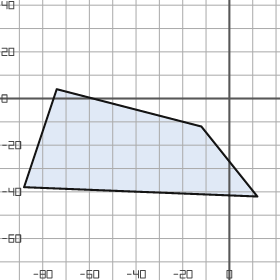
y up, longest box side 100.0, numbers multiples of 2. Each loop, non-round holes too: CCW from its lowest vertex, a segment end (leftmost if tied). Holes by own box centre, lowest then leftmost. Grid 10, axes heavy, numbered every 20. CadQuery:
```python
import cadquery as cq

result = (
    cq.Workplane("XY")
    .moveTo(12.0, -42.0)
    .lineTo(-12.0, -12.0)
    .lineTo(-74.0, 4.0)
    .lineTo(-88.0, -38.0)
    .close()
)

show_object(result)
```